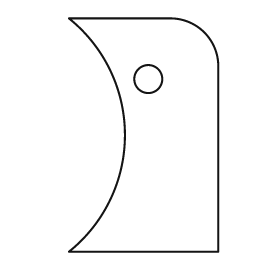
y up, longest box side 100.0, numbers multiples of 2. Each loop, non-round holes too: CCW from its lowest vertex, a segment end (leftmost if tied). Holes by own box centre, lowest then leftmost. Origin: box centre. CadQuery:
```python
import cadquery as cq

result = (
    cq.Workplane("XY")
    .moveTo(-32.0, -50.0)
    .lineTo(32.0, -50.0)
    .lineTo(32.0, 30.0)
    .threePointArc((26.0, 44.0), (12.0, 50.0))
    .lineTo(-32.0, 50.0)
    .threePointArc((-8.0, 0.0), (-32.0, -50.0))
    .close()
    .moveTo(2.0, 24.0)
    .circle(6.0)
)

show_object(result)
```